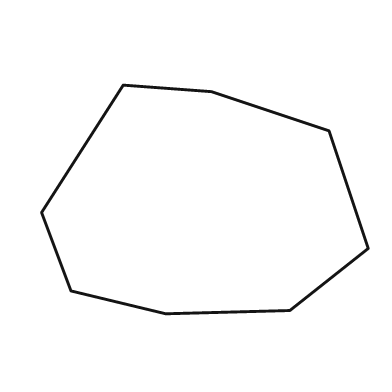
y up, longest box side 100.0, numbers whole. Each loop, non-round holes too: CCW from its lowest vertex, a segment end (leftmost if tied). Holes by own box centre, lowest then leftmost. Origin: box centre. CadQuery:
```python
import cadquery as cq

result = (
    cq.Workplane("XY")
    .moveTo(-12.0, -35.0)
    .lineTo(26.0, -34.0)
    .lineTo(50.0, -15.0)
    .lineTo(38.0, 21.0)
    .lineTo(2.0, 33.0)
    .lineTo(-25.0, 35.0)
    .lineTo(-50.0, -4.0)
    .lineTo(-41.0, -28.0)
    .close()
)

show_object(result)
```